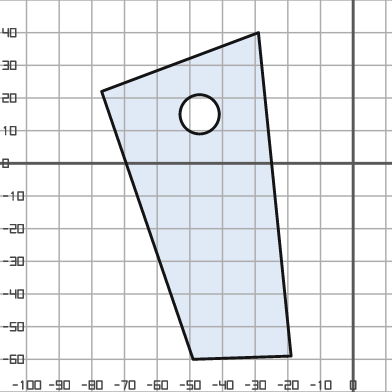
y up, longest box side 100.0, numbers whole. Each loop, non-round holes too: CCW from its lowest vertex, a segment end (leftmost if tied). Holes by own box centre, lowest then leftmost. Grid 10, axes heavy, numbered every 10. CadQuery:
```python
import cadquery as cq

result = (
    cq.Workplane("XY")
    .moveTo(-49.0, -60.0)
    .lineTo(-19.0, -59.0)
    .lineTo(-29.0, 40.0)
    .lineTo(-77.0, 22.0)
    .close()
    .moveTo(-47.0, 15.0)
    .circle(6.0)
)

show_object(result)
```